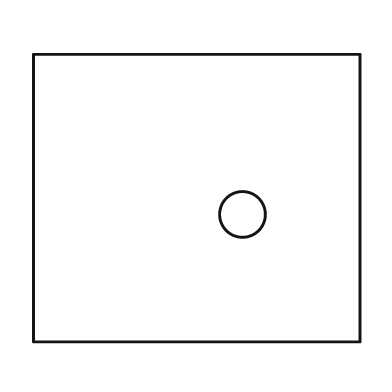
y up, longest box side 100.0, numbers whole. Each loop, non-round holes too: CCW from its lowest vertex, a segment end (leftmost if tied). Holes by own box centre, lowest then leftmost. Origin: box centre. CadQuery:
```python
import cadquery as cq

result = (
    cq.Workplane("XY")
    .moveTo(-50.0, -44.0)
    .lineTo(50.0, -44.0)
    .lineTo(50.0, 44.0)
    .lineTo(-50.0, 44.0)
    .close()
    .moveTo(14.0, -5.0)
    .circle(7.0)
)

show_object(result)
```